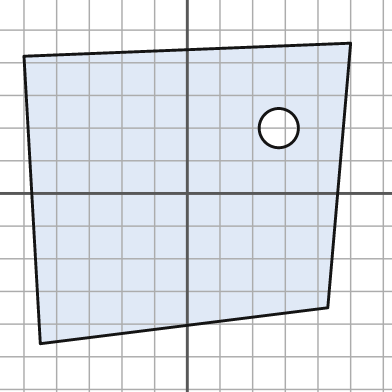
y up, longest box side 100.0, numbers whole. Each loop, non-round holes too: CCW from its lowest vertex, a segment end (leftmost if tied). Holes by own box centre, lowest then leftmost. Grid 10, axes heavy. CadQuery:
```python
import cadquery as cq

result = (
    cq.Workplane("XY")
    .moveTo(-45.0, -46.0)
    .lineTo(43.0, -35.0)
    .lineTo(50.0, 46.0)
    .lineTo(-50.0, 42.0)
    .close()
    .moveTo(28.0, 20.0)
    .circle(6.0)
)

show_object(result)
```